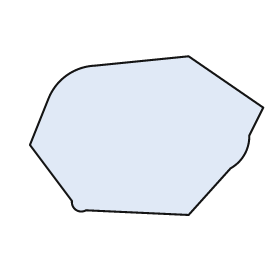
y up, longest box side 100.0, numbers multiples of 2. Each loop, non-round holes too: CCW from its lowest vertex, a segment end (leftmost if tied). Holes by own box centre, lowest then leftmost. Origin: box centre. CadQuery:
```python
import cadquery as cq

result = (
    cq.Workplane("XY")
    .moveTo(18.0, -34.0)
    .lineTo(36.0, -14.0)
    .threePointArc((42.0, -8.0), (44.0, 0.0))
    .lineTo(50.0, 12.0)
    .lineTo(18.0, 34.0)
    .lineTo(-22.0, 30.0)
    .threePointArc((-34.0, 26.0), (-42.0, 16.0))
    .lineTo(-50.0, -4.0)
    .lineTo(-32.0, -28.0)
    .threePointArc((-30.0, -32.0), (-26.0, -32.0))
    .close()
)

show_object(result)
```